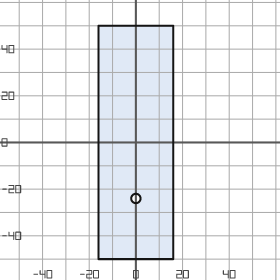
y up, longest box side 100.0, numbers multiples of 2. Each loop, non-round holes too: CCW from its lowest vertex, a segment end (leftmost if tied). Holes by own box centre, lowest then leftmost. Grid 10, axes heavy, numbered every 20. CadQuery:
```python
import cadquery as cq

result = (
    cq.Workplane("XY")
    .moveTo(-16.0, -50.0)
    .lineTo(16.0, -50.0)
    .lineTo(16.0, 50.0)
    .lineTo(-16.0, 50.0)
    .close()
    .moveTo(0.0, -24.0)
    .circle(2.0)
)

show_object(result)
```